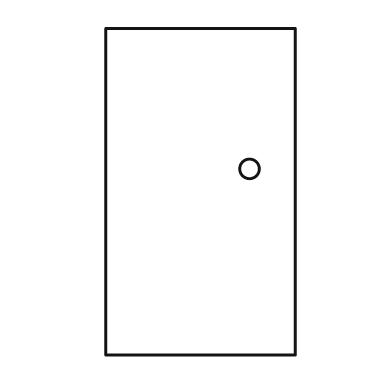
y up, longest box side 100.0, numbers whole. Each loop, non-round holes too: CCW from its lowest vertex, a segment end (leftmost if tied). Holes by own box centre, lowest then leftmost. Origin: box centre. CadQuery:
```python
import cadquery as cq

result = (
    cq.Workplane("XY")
    .moveTo(-29.0, -50.0)
    .lineTo(29.0, -50.0)
    .lineTo(29.0, 50.0)
    .lineTo(-29.0, 50.0)
    .close()
    .moveTo(15.0, 7.0)
    .circle(3.0)
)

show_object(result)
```